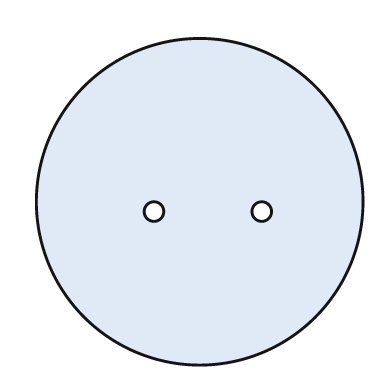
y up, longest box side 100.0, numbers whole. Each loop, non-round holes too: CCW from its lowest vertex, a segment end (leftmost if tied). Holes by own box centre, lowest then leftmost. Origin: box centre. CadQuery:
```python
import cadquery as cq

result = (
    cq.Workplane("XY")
    .moveTo(0.0, 0.0)
    .circle(50.0)
    .moveTo(-14.0, -3.0)
    .circle(3.0)
    .moveTo(19.0, -3.0)
    .circle(3.0)
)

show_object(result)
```